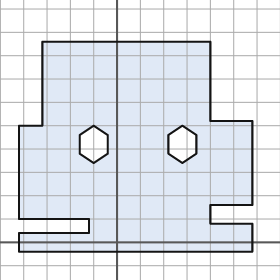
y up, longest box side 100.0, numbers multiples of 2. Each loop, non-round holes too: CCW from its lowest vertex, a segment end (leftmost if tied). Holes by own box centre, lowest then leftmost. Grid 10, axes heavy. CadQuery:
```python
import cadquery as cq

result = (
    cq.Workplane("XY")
    .moveTo(-42.0, -4.0)
    .lineTo(58.0, -4.0)
    .lineTo(58.0, 8.0)
    .lineTo(40.0, 8.0)
    .lineTo(40.0, 16.0)
    .lineTo(58.0, 16.0)
    .lineTo(58.0, 52.0)
    .lineTo(40.0, 52.0)
    .lineTo(40.0, 86.0)
    .lineTo(-32.0, 86.0)
    .lineTo(-32.0, 50.0)
    .lineTo(-42.0, 50.0)
    .lineTo(-42.0, 10.0)
    .lineTo(-12.0, 10.0)
    .lineTo(-12.0, 4.0)
    .lineTo(-42.0, 4.0)
    .close()
    .moveTo(-10.0, 34.0)
    .lineTo(-4.0, 38.0)
    .lineTo(-4.0, 46.0)
    .lineTo(-10.0, 50.0)
    .lineTo(-16.0, 46.0)
    .lineTo(-16.0, 38.0)
    .close()
    .moveTo(28.0, 34.0)
    .lineTo(34.0, 38.0)
    .lineTo(34.0, 46.0)
    .lineTo(28.0, 50.0)
    .lineTo(22.0, 46.0)
    .lineTo(22.0, 38.0)
    .close()
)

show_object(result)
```